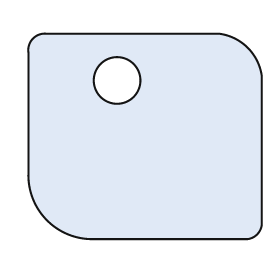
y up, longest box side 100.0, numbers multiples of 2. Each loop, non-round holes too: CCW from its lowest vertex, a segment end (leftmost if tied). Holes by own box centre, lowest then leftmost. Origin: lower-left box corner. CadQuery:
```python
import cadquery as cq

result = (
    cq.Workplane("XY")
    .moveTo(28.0, 0.0)
    .lineTo(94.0, 0.0)
    .threePointArc((98.0, 2.0), (100.0, 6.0))
    .lineTo(100.0, 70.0)
    .threePointArc((94.0, 82.0), (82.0, 88.0))
    .lineTo(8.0, 88.0)
    .threePointArc((2.0, 86.0), (0.0, 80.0))
    .lineTo(0.0, 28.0)
    .threePointArc((8.0, 8.0), (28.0, 0.0))
    .close()
    .moveTo(38.0, 68.0)
    .circle(10.0)
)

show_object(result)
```